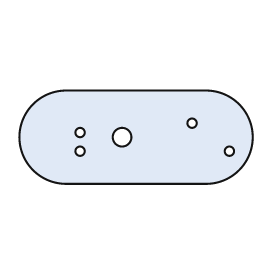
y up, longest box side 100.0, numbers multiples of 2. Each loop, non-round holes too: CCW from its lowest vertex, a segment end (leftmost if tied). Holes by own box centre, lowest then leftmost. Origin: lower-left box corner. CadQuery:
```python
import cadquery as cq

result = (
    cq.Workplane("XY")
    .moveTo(20.0, 0.0)
    .lineTo(80.0, 0.0)
    .threePointArc((100.0, 20.0), (80.0, 40.0))
    .lineTo(20.0, 40.0)
    .threePointArc((0.0, 20.0), (20.0, 0.0))
    .close()
    .moveTo(26.0, 14.0)
    .circle(2.0)
    .moveTo(90.0, 14.0)
    .circle(2.0)
    .moveTo(44.0, 20.0)
    .circle(4.0)
    .moveTo(26.0, 22.0)
    .circle(2.0)
    .moveTo(74.0, 26.0)
    .circle(2.0)
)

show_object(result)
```